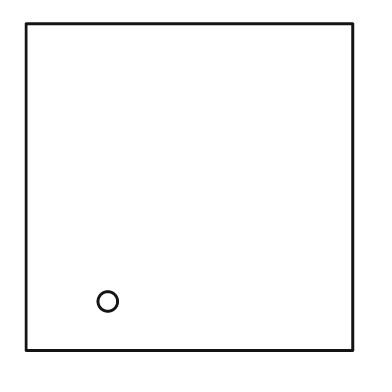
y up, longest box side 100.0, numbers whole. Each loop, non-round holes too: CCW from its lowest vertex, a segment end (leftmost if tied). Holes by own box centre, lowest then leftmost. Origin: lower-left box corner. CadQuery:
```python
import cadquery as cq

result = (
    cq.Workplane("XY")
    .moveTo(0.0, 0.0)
    .lineTo(100.0, 0.0)
    .lineTo(100.0, 100.0)
    .lineTo(0.0, 100.0)
    .close()
    .moveTo(25.0, 15.0)
    .circle(3.0)
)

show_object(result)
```